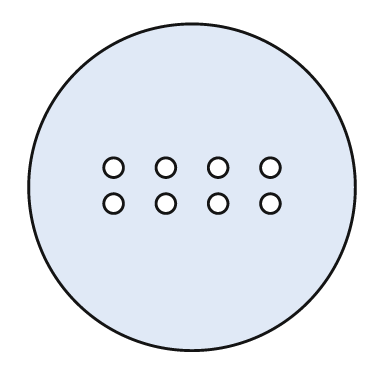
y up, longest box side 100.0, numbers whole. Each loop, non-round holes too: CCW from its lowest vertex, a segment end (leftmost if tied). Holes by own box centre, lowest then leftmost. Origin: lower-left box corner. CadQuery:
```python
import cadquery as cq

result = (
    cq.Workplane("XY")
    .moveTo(50.0, 50.0)
    .circle(50.0)
    .moveTo(26.0, 45.0)
    .circle(3.0)
    .moveTo(42.0, 45.0)
    .circle(3.0)
    .moveTo(58.0, 45.0)
    .circle(3.0)
    .moveTo(74.0, 45.0)
    .circle(3.0)
    .moveTo(26.0, 56.0)
    .circle(3.0)
    .moveTo(42.0, 56.0)
    .circle(3.0)
    .moveTo(58.0, 56.0)
    .circle(3.0)
    .moveTo(74.0, 56.0)
    .circle(3.0)
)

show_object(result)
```